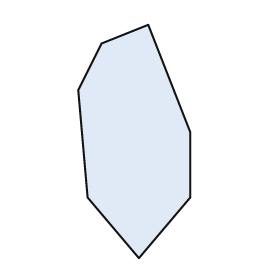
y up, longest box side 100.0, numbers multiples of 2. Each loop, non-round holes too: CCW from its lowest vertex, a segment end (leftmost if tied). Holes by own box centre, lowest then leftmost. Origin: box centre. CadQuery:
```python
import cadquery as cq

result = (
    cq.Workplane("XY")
    .moveTo(2.0, -50.0)
    .lineTo(24.0, -24.0)
    .lineTo(24.0, 4.0)
    .lineTo(6.0, 50.0)
    .lineTo(-14.0, 42.0)
    .lineTo(-24.0, 22.0)
    .lineTo(-20.0, -24.0)
    .close()
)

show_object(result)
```